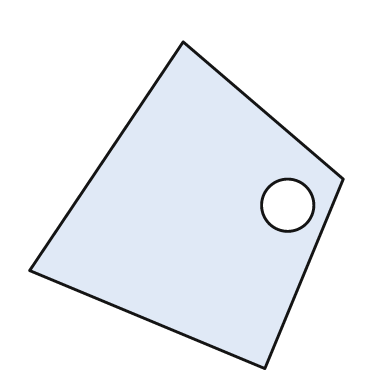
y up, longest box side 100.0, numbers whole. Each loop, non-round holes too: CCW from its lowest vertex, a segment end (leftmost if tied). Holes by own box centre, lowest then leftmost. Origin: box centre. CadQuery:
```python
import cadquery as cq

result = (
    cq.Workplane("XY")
    .moveTo(24.0, -50.0)
    .lineTo(48.0, 8.0)
    .lineTo(-1.0, 50.0)
    .lineTo(-48.0, -20.0)
    .close()
    .moveTo(31.0, 0.0)
    .circle(8.0)
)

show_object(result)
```